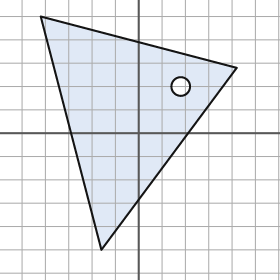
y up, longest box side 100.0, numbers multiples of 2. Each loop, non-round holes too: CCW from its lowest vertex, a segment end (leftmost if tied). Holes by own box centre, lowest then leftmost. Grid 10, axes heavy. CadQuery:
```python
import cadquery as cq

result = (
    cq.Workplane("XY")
    .moveTo(-16.0, -50.0)
    .lineTo(42.0, 28.0)
    .lineTo(-42.0, 50.0)
    .close()
    .moveTo(18.0, 20.0)
    .circle(4.0)
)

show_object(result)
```